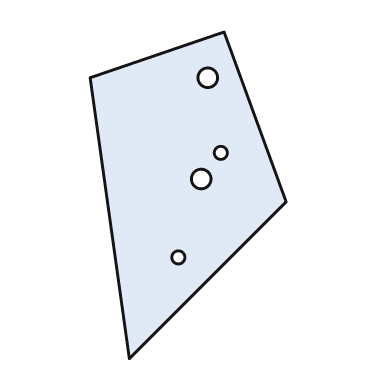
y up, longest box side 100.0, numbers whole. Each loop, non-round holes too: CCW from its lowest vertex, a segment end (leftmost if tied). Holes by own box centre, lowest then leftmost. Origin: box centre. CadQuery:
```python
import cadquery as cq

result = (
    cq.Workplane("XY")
    .moveTo(-18.0, -50.0)
    .lineTo(30.0, -2.0)
    .lineTo(11.0, 50.0)
    .lineTo(-30.0, 36.0)
    .close()
    .moveTo(-3.0, -19.0)
    .circle(2.0)
    .moveTo(4.0, 5.0)
    .circle(3.0)
    .moveTo(10.0, 13.0)
    .circle(2.0)
    .moveTo(6.0, 36.0)
    .circle(3.0)
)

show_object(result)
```